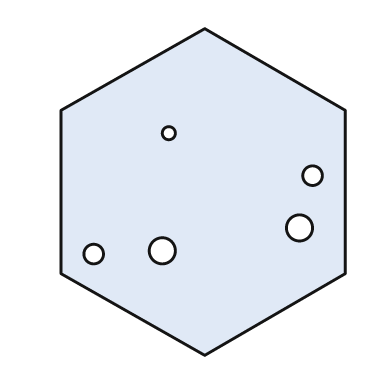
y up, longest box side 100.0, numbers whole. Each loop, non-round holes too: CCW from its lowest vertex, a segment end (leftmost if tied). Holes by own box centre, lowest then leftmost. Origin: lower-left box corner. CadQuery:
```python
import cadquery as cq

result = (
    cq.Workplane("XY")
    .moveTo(44.0, 0.0)
    .lineTo(87.0, 25.0)
    .lineTo(87.0, 75.0)
    .lineTo(44.0, 100.0)
    .lineTo(0.0, 75.0)
    .lineTo(0.0, 25.0)
    .close()
    .moveTo(10.0, 31.0)
    .circle(3.0)
    .moveTo(31.0, 32.0)
    .circle(4.0)
    .moveTo(73.0, 39.0)
    .circle(4.0)
    .moveTo(77.0, 55.0)
    .circle(3.0)
    .moveTo(33.0, 68.0)
    .circle(2.0)
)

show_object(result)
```